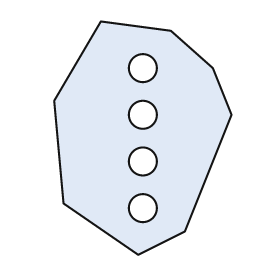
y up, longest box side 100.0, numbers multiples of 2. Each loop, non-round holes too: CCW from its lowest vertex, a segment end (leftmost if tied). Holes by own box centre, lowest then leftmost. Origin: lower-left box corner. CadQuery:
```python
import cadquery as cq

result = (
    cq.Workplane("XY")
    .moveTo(36.0, 0.0)
    .lineTo(56.0, 10.0)
    .lineTo(76.0, 60.0)
    .lineTo(68.0, 80.0)
    .lineTo(50.0, 96.0)
    .lineTo(20.0, 100.0)
    .lineTo(0.0, 66.0)
    .lineTo(4.0, 22.0)
    .close()
    .moveTo(38.0, 20.0)
    .circle(6.0)
    .moveTo(38.0, 40.0)
    .circle(6.0)
    .moveTo(38.0, 60.0)
    .circle(6.0)
    .moveTo(38.0, 80.0)
    .circle(6.0)
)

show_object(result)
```